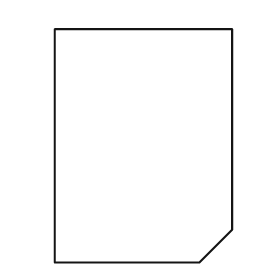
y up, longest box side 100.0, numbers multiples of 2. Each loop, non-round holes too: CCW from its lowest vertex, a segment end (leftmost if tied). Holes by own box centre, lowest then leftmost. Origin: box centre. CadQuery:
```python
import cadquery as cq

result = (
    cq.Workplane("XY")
    .moveTo(-38.0, -50.0)
    .lineTo(24.0, -50.0)
    .lineTo(38.0, -36.0)
    .lineTo(38.0, 50.0)
    .lineTo(-38.0, 50.0)
    .close()
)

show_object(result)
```